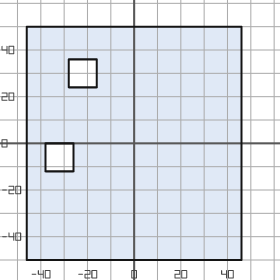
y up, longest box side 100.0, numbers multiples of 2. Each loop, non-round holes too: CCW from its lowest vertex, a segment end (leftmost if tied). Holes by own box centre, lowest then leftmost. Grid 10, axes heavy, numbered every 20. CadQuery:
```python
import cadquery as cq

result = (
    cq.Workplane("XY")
    .moveTo(-46.0, -50.0)
    .lineTo(46.0, -50.0)
    .lineTo(46.0, 50.0)
    .lineTo(-46.0, 50.0)
    .close()
    .moveTo(-38.0, -12.0)
    .lineTo(-26.0, -12.0)
    .lineTo(-26.0, 0.0)
    .lineTo(-38.0, 0.0)
    .close()
    .moveTo(-28.0, 24.0)
    .lineTo(-16.0, 24.0)
    .lineTo(-16.0, 36.0)
    .lineTo(-28.0, 36.0)
    .close()
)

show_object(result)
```